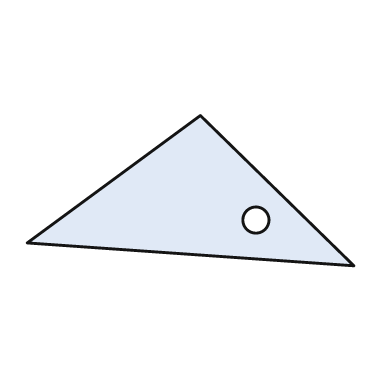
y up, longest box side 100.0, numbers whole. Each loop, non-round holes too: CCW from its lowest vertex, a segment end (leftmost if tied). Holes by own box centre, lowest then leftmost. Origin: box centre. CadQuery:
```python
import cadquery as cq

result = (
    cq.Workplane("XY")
    .moveTo(50.0, -23.0)
    .lineTo(3.0, 23.0)
    .lineTo(-50.0, -16.0)
    .close()
    .moveTo(20.0, -9.0)
    .circle(4.0)
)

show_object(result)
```